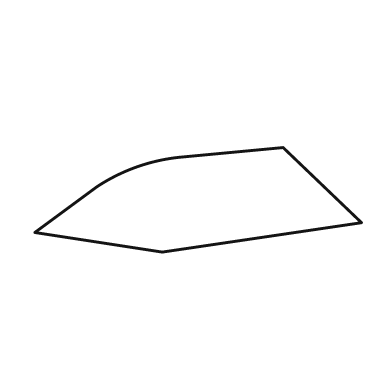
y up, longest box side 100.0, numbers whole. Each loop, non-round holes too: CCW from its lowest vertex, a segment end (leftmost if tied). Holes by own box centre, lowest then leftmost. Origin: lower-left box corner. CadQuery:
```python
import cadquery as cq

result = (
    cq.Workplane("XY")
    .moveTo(39.0, 0.0)
    .lineTo(100.0, 9.0)
    .lineTo(76.0, 32.0)
    .lineTo(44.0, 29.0)
    .threePointArc((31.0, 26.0), (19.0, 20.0))
    .lineTo(0.0, 6.0)
    .close()
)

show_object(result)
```